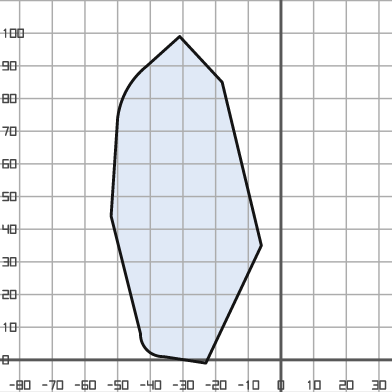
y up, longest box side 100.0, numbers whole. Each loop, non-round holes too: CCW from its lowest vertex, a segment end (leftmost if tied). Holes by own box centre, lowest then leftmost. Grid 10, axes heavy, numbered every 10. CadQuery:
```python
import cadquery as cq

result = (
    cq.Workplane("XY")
    .moveTo(-23.0, -1.0)
    .lineTo(-6.0, 35.0)
    .lineTo(-18.0, 85.0)
    .lineTo(-31.0, 99.0)
    .lineTo(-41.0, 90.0)
    .threePointArc((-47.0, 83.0), (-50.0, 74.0))
    .lineTo(-52.0, 44.0)
    .lineTo(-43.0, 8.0)
    .threePointArc((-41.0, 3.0), (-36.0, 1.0))
    .close()
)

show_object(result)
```